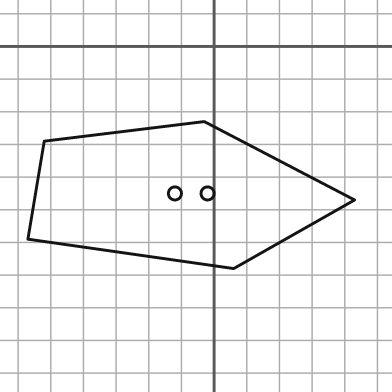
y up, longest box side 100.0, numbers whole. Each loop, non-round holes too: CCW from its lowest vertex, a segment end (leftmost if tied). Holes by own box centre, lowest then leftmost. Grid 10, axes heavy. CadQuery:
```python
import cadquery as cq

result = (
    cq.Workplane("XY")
    .moveTo(6.0, -68.0)
    .lineTo(43.0, -47.0)
    .lineTo(-3.0, -23.0)
    .lineTo(-52.0, -29.0)
    .lineTo(-57.0, -59.0)
    .close()
    .moveTo(-12.0, -45.0)
    .circle(2.0)
    .moveTo(-2.0, -45.0)
    .circle(2.0)
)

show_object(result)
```